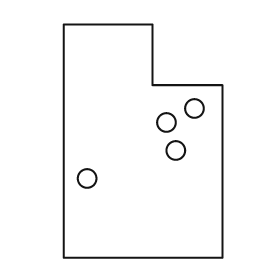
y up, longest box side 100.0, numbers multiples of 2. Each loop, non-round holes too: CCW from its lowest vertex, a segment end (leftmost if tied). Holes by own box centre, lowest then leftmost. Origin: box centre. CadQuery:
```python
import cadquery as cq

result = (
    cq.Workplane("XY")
    .moveTo(-34.0, -50.0)
    .lineTo(34.0, -50.0)
    .lineTo(34.0, 24.0)
    .lineTo(4.0, 24.0)
    .lineTo(4.0, 50.0)
    .lineTo(-34.0, 50.0)
    .close()
    .moveTo(-24.0, -16.0)
    .circle(4.0)
    .moveTo(14.0, -4.0)
    .circle(4.0)
    .moveTo(10.0, 8.0)
    .circle(4.0)
    .moveTo(22.0, 14.0)
    .circle(4.0)
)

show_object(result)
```